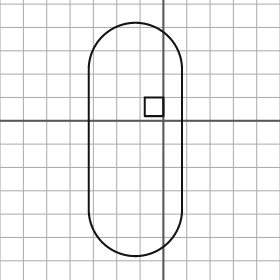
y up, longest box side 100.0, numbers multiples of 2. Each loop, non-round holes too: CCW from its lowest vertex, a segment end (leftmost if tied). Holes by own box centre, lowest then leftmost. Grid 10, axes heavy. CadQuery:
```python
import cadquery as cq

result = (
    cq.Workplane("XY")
    .moveTo(-32.0, -38.0)
    .threePointArc((-12.0, -58.0), (8.0, -38.0))
    .lineTo(8.0, 22.0)
    .threePointArc((-12.0, 42.0), (-32.0, 22.0))
    .close()
    .moveTo(-8.0, 2.0)
    .lineTo(0.0, 2.0)
    .lineTo(0.0, 10.0)
    .lineTo(-8.0, 10.0)
    .close()
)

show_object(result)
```